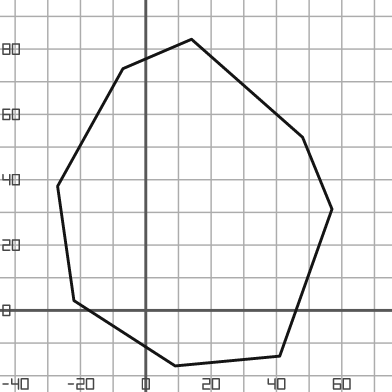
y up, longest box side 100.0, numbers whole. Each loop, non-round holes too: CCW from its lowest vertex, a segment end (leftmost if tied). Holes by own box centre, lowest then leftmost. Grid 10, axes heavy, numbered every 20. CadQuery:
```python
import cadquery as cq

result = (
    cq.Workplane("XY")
    .moveTo(9.0, -17.0)
    .lineTo(41.0, -14.0)
    .lineTo(57.0, 31.0)
    .lineTo(48.0, 53.0)
    .lineTo(14.0, 83.0)
    .lineTo(-7.0, 74.0)
    .lineTo(-27.0, 38.0)
    .lineTo(-22.0, 3.0)
    .close()
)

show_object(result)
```